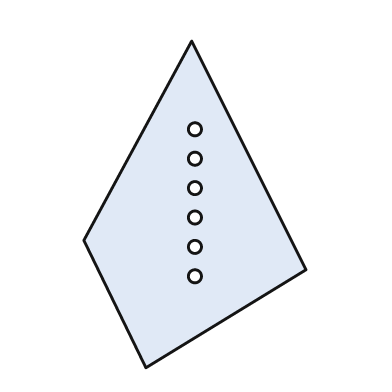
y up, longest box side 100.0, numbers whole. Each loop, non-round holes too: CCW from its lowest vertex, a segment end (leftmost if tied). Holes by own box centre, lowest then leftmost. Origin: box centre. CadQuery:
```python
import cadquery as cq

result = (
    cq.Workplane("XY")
    .moveTo(-15.0, -50.0)
    .lineTo(34.0, -20.0)
    .lineTo(-1.0, 50.0)
    .lineTo(-34.0, -11.0)
    .close()
    .moveTo(0.0, -22.0)
    .circle(2.0)
    .moveTo(0.0, -13.0)
    .circle(2.0)
    .moveTo(0.0, -4.0)
    .circle(2.0)
    .moveTo(0.0, 5.0)
    .circle(2.0)
    .moveTo(0.0, 14.0)
    .circle(2.0)
    .moveTo(0.0, 23.0)
    .circle(2.0)
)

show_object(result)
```